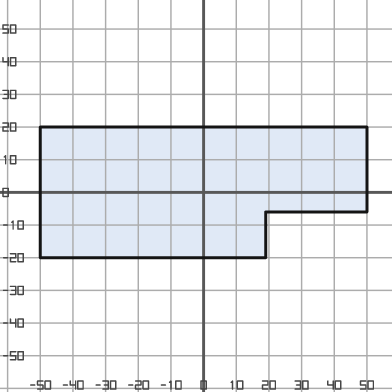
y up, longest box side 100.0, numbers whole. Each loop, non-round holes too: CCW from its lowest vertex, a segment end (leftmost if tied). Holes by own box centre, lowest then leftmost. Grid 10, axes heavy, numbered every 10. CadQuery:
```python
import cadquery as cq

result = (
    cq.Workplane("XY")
    .moveTo(-50.0, -20.0)
    .lineTo(19.0, -20.0)
    .lineTo(19.0, -6.0)
    .lineTo(50.0, -6.0)
    .lineTo(50.0, 20.0)
    .lineTo(-50.0, 20.0)
    .close()
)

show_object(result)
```